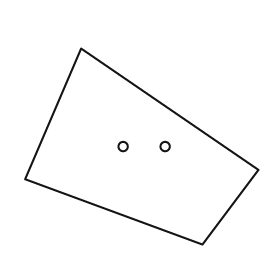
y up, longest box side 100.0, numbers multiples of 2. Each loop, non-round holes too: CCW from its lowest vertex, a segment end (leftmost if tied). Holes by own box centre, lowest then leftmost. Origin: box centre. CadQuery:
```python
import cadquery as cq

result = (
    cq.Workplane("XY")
    .moveTo(26.0, -42.0)
    .lineTo(50.0, -10.0)
    .lineTo(-26.0, 42.0)
    .lineTo(-50.0, -14.0)
    .close()
    .moveTo(-8.0, 0.0)
    .circle(2.0)
    .moveTo(10.0, 0.0)
    .circle(2.0)
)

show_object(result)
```